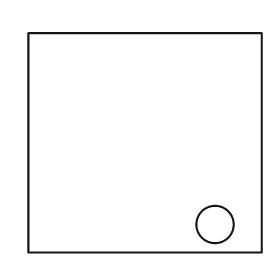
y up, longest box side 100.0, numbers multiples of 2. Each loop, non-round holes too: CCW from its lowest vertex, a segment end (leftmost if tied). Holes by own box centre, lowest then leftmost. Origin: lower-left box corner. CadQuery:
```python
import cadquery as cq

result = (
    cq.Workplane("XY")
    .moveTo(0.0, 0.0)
    .lineTo(100.0, 0.0)
    .lineTo(100.0, 94.0)
    .lineTo(0.0, 94.0)
    .close()
    .moveTo(80.0, 12.0)
    .circle(8.0)
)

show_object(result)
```